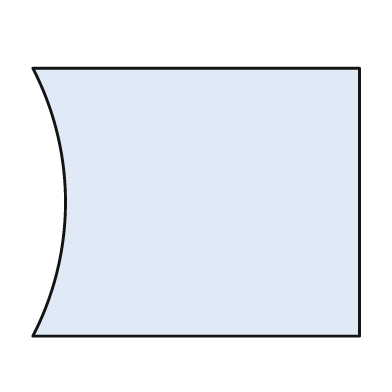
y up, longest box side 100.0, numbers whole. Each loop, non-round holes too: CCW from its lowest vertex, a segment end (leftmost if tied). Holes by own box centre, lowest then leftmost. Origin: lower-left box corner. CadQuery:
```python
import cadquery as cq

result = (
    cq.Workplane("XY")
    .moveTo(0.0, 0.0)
    .lineTo(100.0, 0.0)
    .lineTo(100.0, 82.0)
    .lineTo(0.0, 82.0)
    .threePointArc((10.0, 41.0), (0.0, 0.0))
    .close()
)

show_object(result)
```